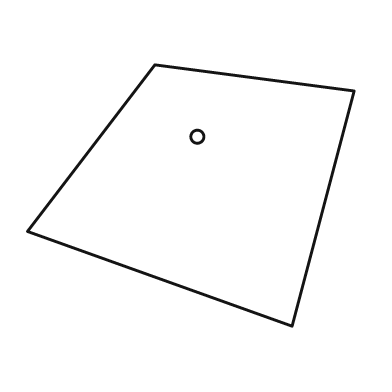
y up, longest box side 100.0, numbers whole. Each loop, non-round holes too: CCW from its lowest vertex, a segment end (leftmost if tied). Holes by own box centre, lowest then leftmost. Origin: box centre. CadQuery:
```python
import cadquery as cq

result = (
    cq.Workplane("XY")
    .moveTo(31.0, -40.0)
    .lineTo(50.0, 32.0)
    .lineTo(-11.0, 40.0)
    .lineTo(-50.0, -11.0)
    .close()
    .moveTo(2.0, 18.0)
    .circle(2.0)
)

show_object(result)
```